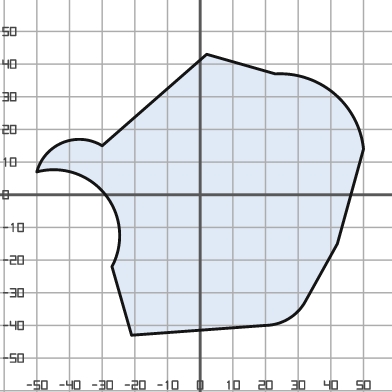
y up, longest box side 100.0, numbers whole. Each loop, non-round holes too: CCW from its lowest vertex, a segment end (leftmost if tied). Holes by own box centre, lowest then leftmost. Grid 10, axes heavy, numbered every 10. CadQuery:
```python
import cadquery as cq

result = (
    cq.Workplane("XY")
    .moveTo(-21.0, -43.0)
    .lineTo(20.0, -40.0)
    .threePointArc((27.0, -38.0), (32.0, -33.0))
    .lineTo(42.0, -15.0)
    .lineTo(50.0, 14.0)
    .threePointArc((41.0, 31.0), (23.0, 37.0))
    .lineTo(2.0, 43.0)
    .lineTo(-30.0, 15.0)
    .threePointArc((-42.0, 16.0), (-50.0, 7.0))
    .threePointArc((-29.0, 0.0), (-27.0, -22.0))
    .close()
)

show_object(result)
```